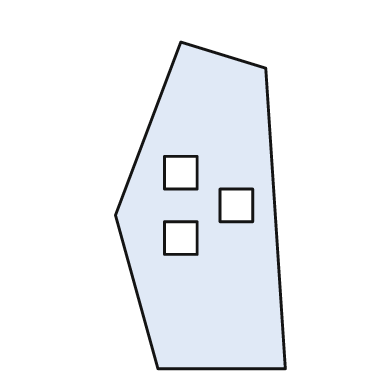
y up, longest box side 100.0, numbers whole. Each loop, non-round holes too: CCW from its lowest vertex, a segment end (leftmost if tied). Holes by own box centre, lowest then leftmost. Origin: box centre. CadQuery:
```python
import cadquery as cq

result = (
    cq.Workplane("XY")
    .moveTo(-13.0, -50.0)
    .lineTo(26.0, -50.0)
    .lineTo(20.0, 42.0)
    .lineTo(-6.0, 50.0)
    .lineTo(-26.0, -3.0)
    .close()
    .moveTo(-11.0, -15.0)
    .lineTo(-1.0, -15.0)
    .lineTo(-1.0, -5.0)
    .lineTo(-11.0, -5.0)
    .close()
    .moveTo(6.0, -5.0)
    .lineTo(16.0, -5.0)
    .lineTo(16.0, 5.0)
    .lineTo(6.0, 5.0)
    .close()
    .moveTo(-11.0, 5.0)
    .lineTo(-1.0, 5.0)
    .lineTo(-1.0, 15.0)
    .lineTo(-11.0, 15.0)
    .close()
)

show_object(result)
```